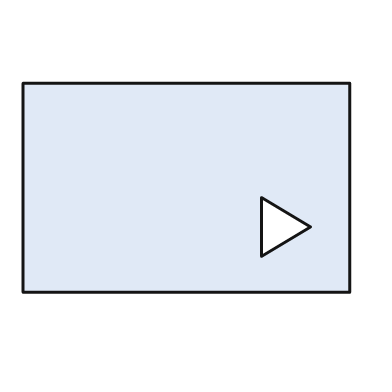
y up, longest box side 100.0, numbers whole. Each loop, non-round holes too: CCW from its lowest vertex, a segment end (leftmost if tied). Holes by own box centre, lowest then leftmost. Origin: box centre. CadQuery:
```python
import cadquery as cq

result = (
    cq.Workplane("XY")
    .moveTo(-50.0, -32.0)
    .lineTo(50.0, -32.0)
    .lineTo(50.0, 32.0)
    .lineTo(-50.0, 32.0)
    .close()
    .moveTo(23.0, -21.0)
    .lineTo(38.0, -12.0)
    .lineTo(23.0, -3.0)
    .close()
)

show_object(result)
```